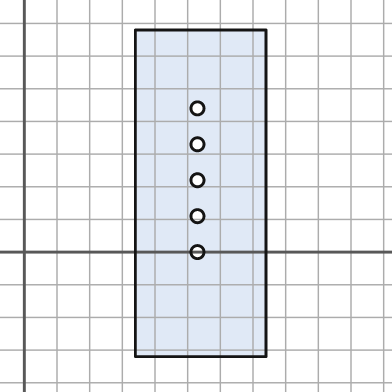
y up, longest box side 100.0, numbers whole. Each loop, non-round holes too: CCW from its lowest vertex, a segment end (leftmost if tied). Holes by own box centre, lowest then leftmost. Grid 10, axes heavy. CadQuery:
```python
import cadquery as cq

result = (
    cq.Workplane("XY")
    .moveTo(34.0, -32.0)
    .lineTo(74.0, -32.0)
    .lineTo(74.0, 68.0)
    .lineTo(34.0, 68.0)
    .close()
    .moveTo(53.0, 0.0)
    .circle(2.0)
    .moveTo(53.0, 11.0)
    .circle(2.0)
    .moveTo(53.0, 22.0)
    .circle(2.0)
    .moveTo(53.0, 33.0)
    .circle(2.0)
    .moveTo(53.0, 44.0)
    .circle(2.0)
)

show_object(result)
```